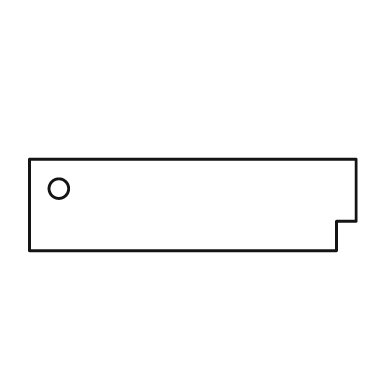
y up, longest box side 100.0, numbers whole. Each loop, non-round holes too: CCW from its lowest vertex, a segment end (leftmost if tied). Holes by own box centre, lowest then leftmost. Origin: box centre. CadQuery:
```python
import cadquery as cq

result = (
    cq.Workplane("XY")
    .moveTo(-50.0, -14.0)
    .lineTo(44.0, -14.0)
    .lineTo(44.0, -5.0)
    .lineTo(50.0, -5.0)
    .lineTo(50.0, 14.0)
    .lineTo(-50.0, 14.0)
    .close()
    .moveTo(-41.0, 5.0)
    .circle(3.0)
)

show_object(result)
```